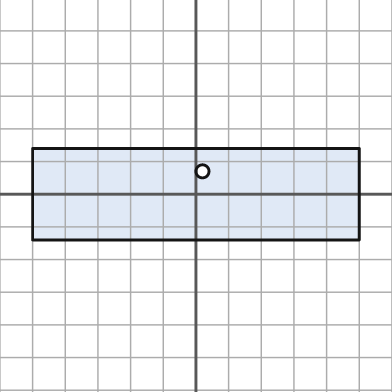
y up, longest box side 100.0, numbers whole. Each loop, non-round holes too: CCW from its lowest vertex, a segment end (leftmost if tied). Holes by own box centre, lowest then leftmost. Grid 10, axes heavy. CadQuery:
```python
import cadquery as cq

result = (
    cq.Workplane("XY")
    .moveTo(-50.0, -14.0)
    .lineTo(50.0, -14.0)
    .lineTo(50.0, 14.0)
    .lineTo(-50.0, 14.0)
    .close()
    .moveTo(2.0, 7.0)
    .circle(2.0)
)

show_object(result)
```